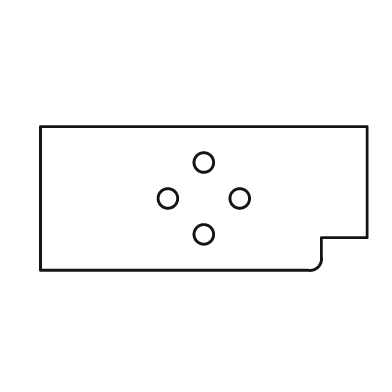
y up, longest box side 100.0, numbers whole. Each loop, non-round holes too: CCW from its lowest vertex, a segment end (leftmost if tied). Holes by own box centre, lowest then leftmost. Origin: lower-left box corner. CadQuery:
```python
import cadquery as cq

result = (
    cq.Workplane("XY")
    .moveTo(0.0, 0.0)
    .lineTo(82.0, 0.0)
    .threePointArc((85.0, 1.0), (86.0, 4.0))
    .lineTo(86.0, 10.0)
    .lineTo(100.0, 10.0)
    .lineTo(100.0, 44.0)
    .lineTo(0.0, 44.0)
    .close()
    .moveTo(50.0, 11.0)
    .circle(3.0)
    .moveTo(39.0, 22.0)
    .circle(3.0)
    .moveTo(61.0, 22.0)
    .circle(3.0)
    .moveTo(50.0, 33.0)
    .circle(3.0)
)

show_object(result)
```